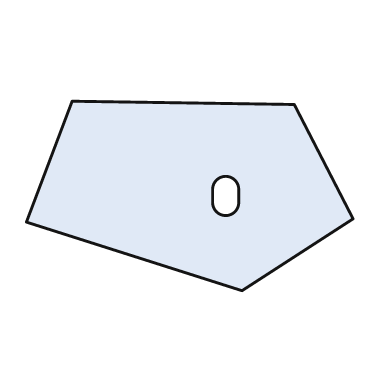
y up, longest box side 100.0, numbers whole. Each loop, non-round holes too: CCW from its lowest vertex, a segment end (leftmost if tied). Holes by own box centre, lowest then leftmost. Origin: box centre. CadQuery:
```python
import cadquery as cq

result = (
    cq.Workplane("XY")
    .moveTo(16.0, -29.0)
    .lineTo(50.0, -7.0)
    .lineTo(32.0, 28.0)
    .lineTo(-36.0, 29.0)
    .lineTo(-50.0, -8.0)
    .close()
    .moveTo(7.0, -2.0)
    .threePointArc((11.0, -6.0), (15.0, -2.0))
    .lineTo(15.0, 2.0)
    .threePointArc((11.0, 6.0), (7.0, 2.0))
    .close()
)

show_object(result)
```